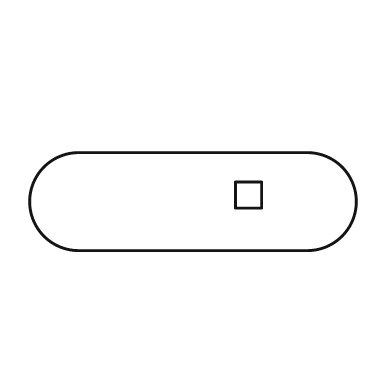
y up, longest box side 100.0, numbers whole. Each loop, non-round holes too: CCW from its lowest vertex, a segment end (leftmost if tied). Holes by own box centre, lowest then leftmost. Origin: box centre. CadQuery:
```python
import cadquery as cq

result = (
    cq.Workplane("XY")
    .moveTo(-35.0, -15.0)
    .lineTo(35.0, -15.0)
    .threePointArc((50.0, 0.0), (35.0, 15.0))
    .lineTo(-35.0, 15.0)
    .threePointArc((-50.0, 0.0), (-35.0, -15.0))
    .close()
    .moveTo(13.0, -2.0)
    .lineTo(21.0, -2.0)
    .lineTo(21.0, 6.0)
    .lineTo(13.0, 6.0)
    .close()
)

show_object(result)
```